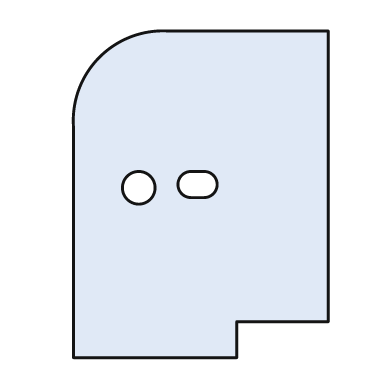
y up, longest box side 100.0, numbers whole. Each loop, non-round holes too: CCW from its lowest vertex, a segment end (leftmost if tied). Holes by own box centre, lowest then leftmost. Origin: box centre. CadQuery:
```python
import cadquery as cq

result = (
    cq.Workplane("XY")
    .moveTo(-39.0, -50.0)
    .lineTo(11.0, -50.0)
    .lineTo(11.0, -39.0)
    .lineTo(39.0, -39.0)
    .lineTo(39.0, 50.0)
    .lineTo(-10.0, 50.0)
    .threePointArc((-31.0, 42.0), (-39.0, 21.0))
    .close()
    .moveTo(-19.0, 2.0)
    .circle(5.0)
    .moveTo(-3.0, -1.0)
    .lineTo(1.0, -1.0)
    .threePointArc((5.0, 3.0), (1.0, 7.0))
    .lineTo(-3.0, 7.0)
    .threePointArc((-7.0, 3.0), (-3.0, -1.0))
    .close()
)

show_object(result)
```